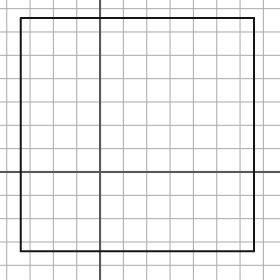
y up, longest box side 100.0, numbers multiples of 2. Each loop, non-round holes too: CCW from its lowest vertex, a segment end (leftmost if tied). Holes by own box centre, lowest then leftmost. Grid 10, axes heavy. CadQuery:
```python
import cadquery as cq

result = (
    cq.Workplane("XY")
    .moveTo(-34.0, -34.0)
    .lineTo(66.0, -34.0)
    .lineTo(66.0, 66.0)
    .lineTo(-34.0, 66.0)
    .close()
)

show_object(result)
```